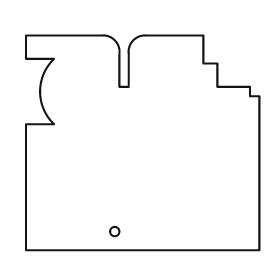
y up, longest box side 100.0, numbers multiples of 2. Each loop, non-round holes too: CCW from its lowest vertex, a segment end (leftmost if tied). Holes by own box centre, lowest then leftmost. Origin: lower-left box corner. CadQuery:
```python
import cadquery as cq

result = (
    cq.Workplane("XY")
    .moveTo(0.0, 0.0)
    .lineTo(100.0, 0.0)
    .lineTo(100.0, 66.0)
    .lineTo(96.0, 66.0)
    .lineTo(96.0, 70.0)
    .lineTo(82.0, 70.0)
    .lineTo(82.0, 80.0)
    .lineTo(76.0, 80.0)
    .lineTo(76.0, 92.0)
    .lineTo(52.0, 92.0)
    .threePointArc((46.0, 90.0), (44.0, 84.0))
    .lineTo(44.0, 70.0)
    .lineTo(40.0, 70.0)
    .lineTo(40.0, 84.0)
    .threePointArc((38.0, 90.0), (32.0, 92.0))
    .lineTo(0.0, 92.0)
    .lineTo(0.0, 82.0)
    .lineTo(12.0, 82.0)
    .threePointArc((6.0, 68.0), (12.0, 54.0))
    .lineTo(0.0, 54.0)
    .close()
    .moveTo(38.0, 8.0)
    .circle(2.0)
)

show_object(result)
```